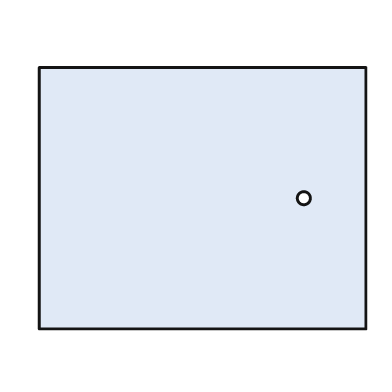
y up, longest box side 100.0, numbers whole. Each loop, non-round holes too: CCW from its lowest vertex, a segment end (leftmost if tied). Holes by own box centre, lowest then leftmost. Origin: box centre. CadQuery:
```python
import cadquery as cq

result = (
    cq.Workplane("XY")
    .moveTo(-50.0, -40.0)
    .lineTo(50.0, -40.0)
    .lineTo(50.0, 40.0)
    .lineTo(-50.0, 40.0)
    .close()
    .moveTo(31.0, 0.0)
    .circle(2.0)
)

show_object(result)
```